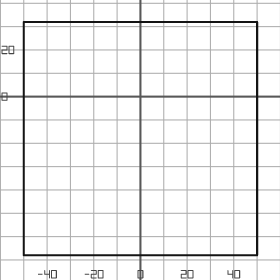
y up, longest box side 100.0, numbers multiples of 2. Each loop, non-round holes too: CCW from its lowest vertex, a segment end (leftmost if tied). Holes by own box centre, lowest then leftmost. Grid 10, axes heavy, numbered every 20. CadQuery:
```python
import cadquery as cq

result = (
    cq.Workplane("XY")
    .moveTo(-50.0, -68.0)
    .lineTo(50.0, -68.0)
    .lineTo(50.0, 32.0)
    .lineTo(-50.0, 32.0)
    .close()
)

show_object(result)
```